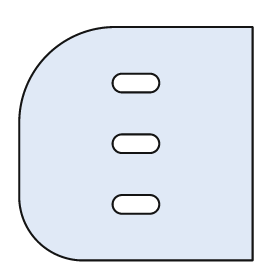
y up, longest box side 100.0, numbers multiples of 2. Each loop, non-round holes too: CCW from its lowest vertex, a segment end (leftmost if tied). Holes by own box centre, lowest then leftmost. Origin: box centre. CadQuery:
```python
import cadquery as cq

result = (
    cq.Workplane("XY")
    .moveTo(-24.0, -50.0)
    .lineTo(50.0, -50.0)
    .lineTo(50.0, 50.0)
    .lineTo(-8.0, 50.0)
    .threePointArc((-38.0, 38.0), (-50.0, 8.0))
    .lineTo(-50.0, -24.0)
    .threePointArc((-42.0, -42.0), (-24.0, -50.0))
    .close()
    .moveTo(-6.0, -30.0)
    .lineTo(6.0, -30.0)
    .threePointArc((10.0, -26.0), (6.0, -22.0))
    .lineTo(-6.0, -22.0)
    .threePointArc((-10.0, -26.0), (-6.0, -30.0))
    .close()
    .moveTo(-6.0, -4.0)
    .lineTo(6.0, -4.0)
    .threePointArc((10.0, 0.0), (6.0, 4.0))
    .lineTo(-6.0, 4.0)
    .threePointArc((-10.0, 0.0), (-6.0, -4.0))
    .close()
    .moveTo(-6.0, 22.0)
    .lineTo(6.0, 22.0)
    .threePointArc((10.0, 26.0), (6.0, 30.0))
    .lineTo(-6.0, 30.0)
    .threePointArc((-10.0, 26.0), (-6.0, 22.0))
    .close()
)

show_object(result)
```